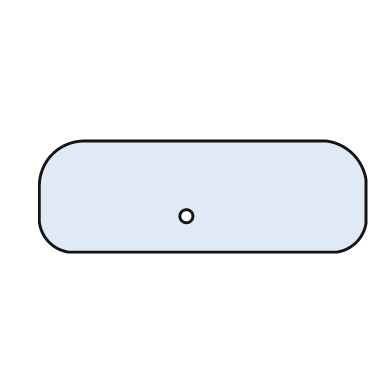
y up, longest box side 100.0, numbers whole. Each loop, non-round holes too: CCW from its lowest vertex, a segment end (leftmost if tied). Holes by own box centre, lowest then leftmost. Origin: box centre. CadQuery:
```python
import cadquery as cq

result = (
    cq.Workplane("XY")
    .moveTo(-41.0, -17.0)
    .lineTo(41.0, -17.0)
    .threePointArc((47.0, -14.0), (50.0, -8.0))
    .lineTo(50.0, 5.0)
    .threePointArc((46.0, 13.0), (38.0, 17.0))
    .lineTo(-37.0, 17.0)
    .threePointArc((-46.0, 13.0), (-50.0, 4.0))
    .lineTo(-50.0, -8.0)
    .threePointArc((-47.0, -14.0), (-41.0, -17.0))
    .close()
    .moveTo(-5.0, -6.0)
    .circle(2.0)
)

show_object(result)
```